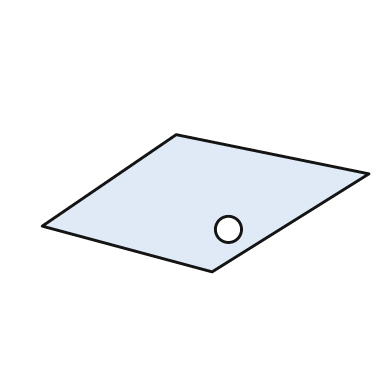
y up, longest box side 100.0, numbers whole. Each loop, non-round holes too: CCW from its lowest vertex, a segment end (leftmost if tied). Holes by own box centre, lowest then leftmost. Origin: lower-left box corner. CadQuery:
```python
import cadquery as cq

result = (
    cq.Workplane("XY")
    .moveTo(52.0, 0.0)
    .lineTo(100.0, 30.0)
    .lineTo(41.0, 42.0)
    .lineTo(0.0, 14.0)
    .close()
    .moveTo(57.0, 13.0)
    .circle(4.0)
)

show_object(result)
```